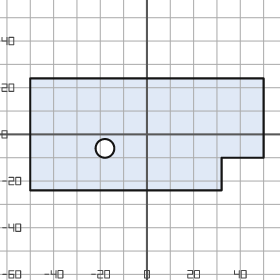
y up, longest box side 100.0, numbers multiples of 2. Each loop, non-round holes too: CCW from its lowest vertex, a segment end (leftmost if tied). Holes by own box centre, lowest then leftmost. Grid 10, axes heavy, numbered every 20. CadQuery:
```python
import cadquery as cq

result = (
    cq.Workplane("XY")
    .moveTo(-50.0, -24.0)
    .lineTo(32.0, -24.0)
    .lineTo(32.0, -10.0)
    .lineTo(50.0, -10.0)
    .lineTo(50.0, 24.0)
    .lineTo(-50.0, 24.0)
    .close()
    .moveTo(-18.0, -6.0)
    .circle(4.0)
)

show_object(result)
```